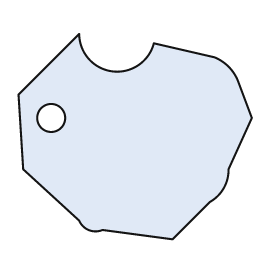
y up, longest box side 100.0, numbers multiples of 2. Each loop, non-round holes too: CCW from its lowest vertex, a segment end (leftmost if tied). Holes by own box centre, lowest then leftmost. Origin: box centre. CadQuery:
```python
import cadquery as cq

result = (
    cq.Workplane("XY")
    .moveTo(16.0, -44.0)
    .lineTo(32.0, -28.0)
    .threePointArc((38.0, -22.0), (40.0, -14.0))
    .lineTo(50.0, 8.0)
    .lineTo(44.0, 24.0)
    .threePointArc((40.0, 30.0), (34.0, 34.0))
    .lineTo(8.0, 40.0)
    .threePointArc((-10.0, 28.0), (-24.0, 44.0))
    .lineTo(-50.0, 18.0)
    .lineTo(-48.0, -14.0)
    .lineTo(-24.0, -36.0)
    .threePointArc((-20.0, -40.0), (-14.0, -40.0))
    .close()
    .moveTo(-36.0, 8.0)
    .circle(6.0)
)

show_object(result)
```